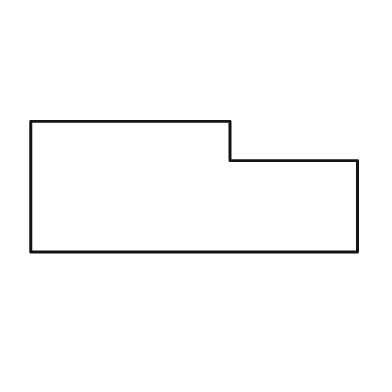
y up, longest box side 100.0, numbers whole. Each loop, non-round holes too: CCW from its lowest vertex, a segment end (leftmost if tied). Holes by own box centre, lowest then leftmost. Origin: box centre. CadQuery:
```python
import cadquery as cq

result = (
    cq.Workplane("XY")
    .moveTo(-50.0, -20.0)
    .lineTo(50.0, -20.0)
    .lineTo(50.0, 8.0)
    .lineTo(11.0, 8.0)
    .lineTo(11.0, 20.0)
    .lineTo(-50.0, 20.0)
    .close()
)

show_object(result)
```